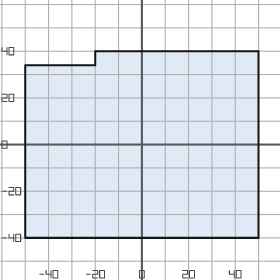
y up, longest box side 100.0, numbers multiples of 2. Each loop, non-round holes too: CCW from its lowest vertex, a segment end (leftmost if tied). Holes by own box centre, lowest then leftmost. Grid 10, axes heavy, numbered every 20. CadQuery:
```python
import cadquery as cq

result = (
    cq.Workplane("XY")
    .moveTo(-50.0, -40.0)
    .lineTo(50.0, -40.0)
    .lineTo(50.0, 40.0)
    .lineTo(-20.0, 40.0)
    .lineTo(-20.0, 34.0)
    .lineTo(-50.0, 34.0)
    .close()
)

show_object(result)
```